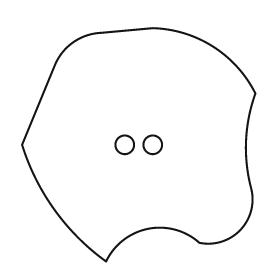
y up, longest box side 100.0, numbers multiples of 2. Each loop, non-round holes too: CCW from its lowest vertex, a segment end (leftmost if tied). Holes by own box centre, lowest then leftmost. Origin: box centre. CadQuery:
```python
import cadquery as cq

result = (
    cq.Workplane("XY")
    .moveTo(-14.0, -50.0)
    .threePointArc((4.0, -36.0), (26.0, -42.0))
    .threePointArc((44.0, -36.0), (48.0, -18.0))
    .threePointArc((46.0, 2.0), (50.0, 22.0))
    .threePointArc((32.0, 42.0), (6.0, 50.0))
    .lineTo(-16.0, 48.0)
    .threePointArc((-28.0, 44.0), (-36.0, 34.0))
    .lineTo(-50.0, 0.0)
    .threePointArc((-36.0, -28.0), (-14.0, -50.0))
    .close()
    .moveTo(-6.0, 0.0)
    .circle(4.0)
    .moveTo(6.0, 0.0)
    .circle(4.0)
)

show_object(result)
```